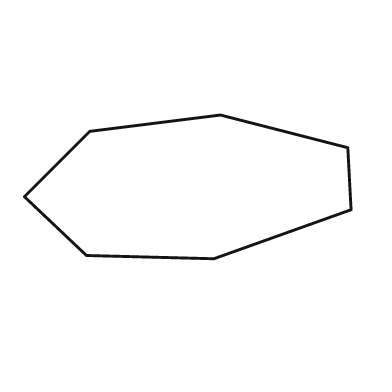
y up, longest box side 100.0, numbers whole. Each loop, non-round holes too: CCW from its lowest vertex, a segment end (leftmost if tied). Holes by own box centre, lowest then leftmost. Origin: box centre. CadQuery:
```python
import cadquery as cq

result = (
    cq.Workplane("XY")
    .moveTo(8.0, -22.0)
    .lineTo(50.0, -7.0)
    .lineTo(49.0, 12.0)
    .lineTo(10.0, 22.0)
    .lineTo(-30.0, 17.0)
    .lineTo(-50.0, -3.0)
    .lineTo(-31.0, -21.0)
    .close()
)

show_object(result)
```